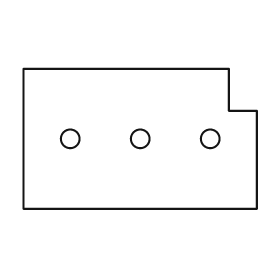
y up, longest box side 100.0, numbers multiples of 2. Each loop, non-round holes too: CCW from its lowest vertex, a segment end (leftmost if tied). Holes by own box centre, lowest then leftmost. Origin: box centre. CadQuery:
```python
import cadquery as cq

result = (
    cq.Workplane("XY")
    .moveTo(-50.0, -30.0)
    .lineTo(50.0, -30.0)
    .lineTo(50.0, 12.0)
    .lineTo(38.0, 12.0)
    .lineTo(38.0, 30.0)
    .lineTo(-50.0, 30.0)
    .close()
    .moveTo(-30.0, 0.0)
    .circle(4.0)
    .moveTo(0.0, 0.0)
    .circle(4.0)
    .moveTo(30.0, 0.0)
    .circle(4.0)
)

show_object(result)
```